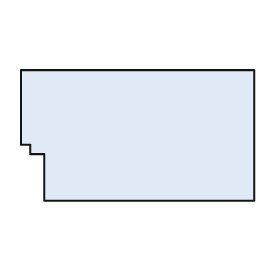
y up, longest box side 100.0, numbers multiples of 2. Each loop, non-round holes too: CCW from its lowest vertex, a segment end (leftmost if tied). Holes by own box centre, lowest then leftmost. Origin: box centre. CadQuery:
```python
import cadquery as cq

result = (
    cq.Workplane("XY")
    .moveTo(-40.0, -28.0)
    .lineTo(50.0, -28.0)
    .lineTo(50.0, 28.0)
    .lineTo(-50.0, 28.0)
    .lineTo(-50.0, -4.0)
    .lineTo(-46.0, -4.0)
    .lineTo(-46.0, -8.0)
    .lineTo(-40.0, -8.0)
    .close()
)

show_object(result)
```